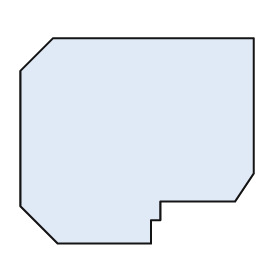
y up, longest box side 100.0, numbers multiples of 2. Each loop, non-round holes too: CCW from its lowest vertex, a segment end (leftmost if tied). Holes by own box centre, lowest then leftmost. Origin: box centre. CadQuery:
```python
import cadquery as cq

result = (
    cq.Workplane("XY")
    .moveTo(-34.0, -44.0)
    .lineTo(6.0, -44.0)
    .lineTo(6.0, -34.0)
    .lineTo(10.0, -34.0)
    .lineTo(10.0, -26.0)
    .lineTo(42.0, -26.0)
    .lineTo(50.0, -14.0)
    .lineTo(50.0, 44.0)
    .lineTo(-36.0, 44.0)
    .lineTo(-50.0, 30.0)
    .lineTo(-50.0, -28.0)
    .close()
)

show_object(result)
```